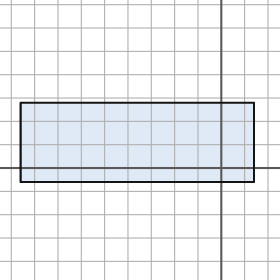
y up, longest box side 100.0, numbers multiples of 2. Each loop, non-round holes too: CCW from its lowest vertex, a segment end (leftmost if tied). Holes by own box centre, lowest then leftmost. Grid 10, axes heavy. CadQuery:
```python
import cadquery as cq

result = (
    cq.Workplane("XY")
    .moveTo(-86.0, -6.0)
    .lineTo(14.0, -6.0)
    .lineTo(14.0, 28.0)
    .lineTo(-86.0, 28.0)
    .close()
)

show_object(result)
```